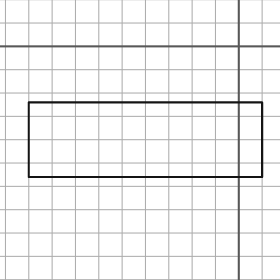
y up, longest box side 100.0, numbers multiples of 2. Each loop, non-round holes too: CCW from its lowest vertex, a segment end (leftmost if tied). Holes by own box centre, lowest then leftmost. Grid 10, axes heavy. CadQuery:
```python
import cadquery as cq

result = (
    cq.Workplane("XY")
    .moveTo(-90.0, -56.0)
    .lineTo(10.0, -56.0)
    .lineTo(10.0, -24.0)
    .lineTo(-90.0, -24.0)
    .close()
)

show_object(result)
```